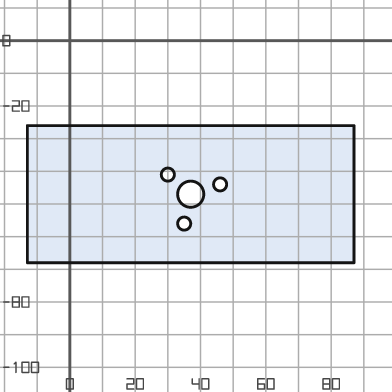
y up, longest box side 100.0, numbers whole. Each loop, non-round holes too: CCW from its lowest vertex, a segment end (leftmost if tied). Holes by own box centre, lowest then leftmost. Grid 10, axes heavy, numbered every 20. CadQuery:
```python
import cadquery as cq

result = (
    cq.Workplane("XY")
    .moveTo(-13.0, -68.0)
    .lineTo(87.0, -68.0)
    .lineTo(87.0, -26.0)
    .lineTo(-13.0, -26.0)
    .close()
    .moveTo(35.0, -56.0)
    .circle(2.0)
    .moveTo(37.0, -47.0)
    .circle(4.0)
    .moveTo(46.0, -44.0)
    .circle(2.0)
    .moveTo(30.0, -41.0)
    .circle(2.0)
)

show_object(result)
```